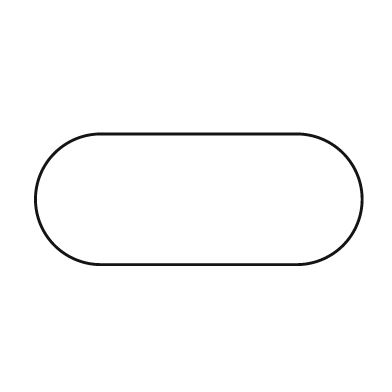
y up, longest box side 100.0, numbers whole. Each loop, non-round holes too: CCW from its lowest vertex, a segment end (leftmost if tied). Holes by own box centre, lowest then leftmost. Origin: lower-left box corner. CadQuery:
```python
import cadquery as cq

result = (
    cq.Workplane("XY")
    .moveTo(20.0, 0.0)
    .lineTo(80.0, 0.0)
    .threePointArc((100.0, 20.0), (80.0, 40.0))
    .lineTo(20.0, 40.0)
    .threePointArc((0.0, 20.0), (20.0, 0.0))
    .close()
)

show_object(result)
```